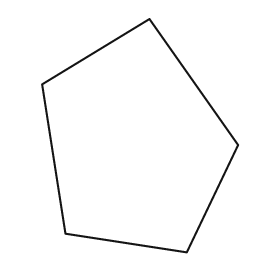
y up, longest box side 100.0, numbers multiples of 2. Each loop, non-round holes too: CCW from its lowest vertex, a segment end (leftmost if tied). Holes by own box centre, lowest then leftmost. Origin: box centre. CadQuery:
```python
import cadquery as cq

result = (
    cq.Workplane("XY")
    .moveTo(20.0, -50.0)
    .lineTo(42.0, -4.0)
    .lineTo(4.0, 50.0)
    .lineTo(-42.0, 22.0)
    .lineTo(-32.0, -42.0)
    .close()
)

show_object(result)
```